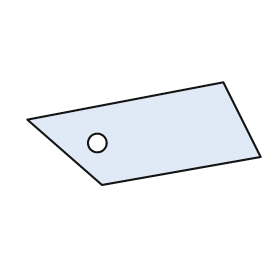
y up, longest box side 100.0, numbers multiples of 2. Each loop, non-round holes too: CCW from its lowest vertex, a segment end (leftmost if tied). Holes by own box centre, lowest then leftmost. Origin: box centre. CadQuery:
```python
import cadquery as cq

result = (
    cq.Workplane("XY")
    .moveTo(-18.0, -22.0)
    .lineTo(50.0, -10.0)
    .lineTo(34.0, 22.0)
    .lineTo(-50.0, 6.0)
    .close()
    .moveTo(-20.0, -4.0)
    .circle(4.0)
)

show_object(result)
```